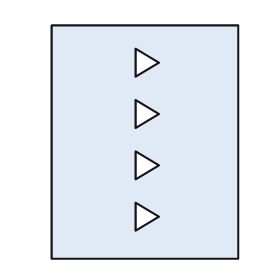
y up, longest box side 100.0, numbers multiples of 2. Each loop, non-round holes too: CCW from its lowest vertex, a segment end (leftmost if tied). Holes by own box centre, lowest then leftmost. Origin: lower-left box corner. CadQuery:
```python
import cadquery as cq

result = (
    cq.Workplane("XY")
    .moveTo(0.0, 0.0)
    .lineTo(80.0, 0.0)
    .lineTo(80.0, 100.0)
    .lineTo(0.0, 100.0)
    .close()
    .moveTo(36.0, 12.0)
    .lineTo(46.0, 18.0)
    .lineTo(36.0, 24.0)
    .close()
    .moveTo(36.0, 34.0)
    .lineTo(46.0, 40.0)
    .lineTo(36.0, 46.0)
    .close()
    .moveTo(36.0, 56.0)
    .lineTo(46.0, 62.0)
    .lineTo(36.0, 68.0)
    .close()
    .moveTo(36.0, 78.0)
    .lineTo(46.0, 84.0)
    .lineTo(36.0, 90.0)
    .close()
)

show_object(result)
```